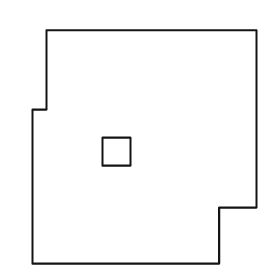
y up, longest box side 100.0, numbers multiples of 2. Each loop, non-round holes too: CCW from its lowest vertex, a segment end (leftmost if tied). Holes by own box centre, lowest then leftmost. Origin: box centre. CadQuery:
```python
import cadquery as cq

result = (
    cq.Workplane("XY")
    .moveTo(-48.0, -50.0)
    .lineTo(32.0, -50.0)
    .lineTo(32.0, -26.0)
    .lineTo(48.0, -26.0)
    .lineTo(48.0, 50.0)
    .lineTo(-42.0, 50.0)
    .lineTo(-42.0, 16.0)
    .lineTo(-48.0, 16.0)
    .close()
    .moveTo(-18.0, -8.0)
    .lineTo(-6.0, -8.0)
    .lineTo(-6.0, 4.0)
    .lineTo(-18.0, 4.0)
    .close()
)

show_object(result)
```